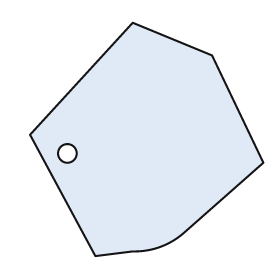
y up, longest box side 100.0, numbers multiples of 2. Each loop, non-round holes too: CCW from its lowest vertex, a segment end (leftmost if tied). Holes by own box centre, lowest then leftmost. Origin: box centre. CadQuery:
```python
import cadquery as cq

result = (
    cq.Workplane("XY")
    .moveTo(-22.0, -50.0)
    .lineTo(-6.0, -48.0)
    .threePointArc((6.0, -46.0), (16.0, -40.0))
    .lineTo(50.0, -10.0)
    .lineTo(28.0, 36.0)
    .lineTo(-6.0, 50.0)
    .lineTo(-50.0, 2.0)
    .close()
    .moveTo(-34.0, -6.0)
    .circle(4.0)
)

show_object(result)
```